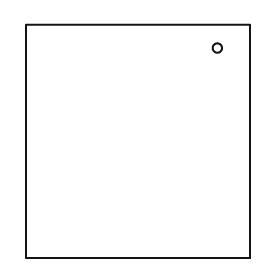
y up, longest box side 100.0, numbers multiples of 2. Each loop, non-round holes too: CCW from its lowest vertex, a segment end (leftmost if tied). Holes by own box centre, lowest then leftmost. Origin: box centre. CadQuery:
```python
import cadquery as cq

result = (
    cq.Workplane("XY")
    .moveTo(-48.0, -50.0)
    .lineTo(48.0, -50.0)
    .lineTo(48.0, 50.0)
    .lineTo(-48.0, 50.0)
    .close()
    .moveTo(34.0, 40.0)
    .circle(2.0)
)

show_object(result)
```